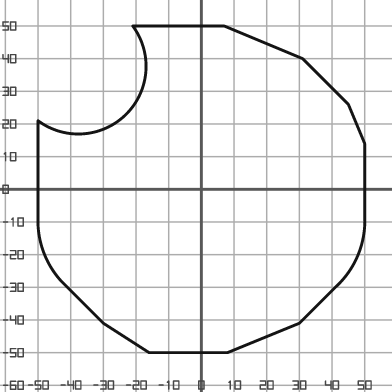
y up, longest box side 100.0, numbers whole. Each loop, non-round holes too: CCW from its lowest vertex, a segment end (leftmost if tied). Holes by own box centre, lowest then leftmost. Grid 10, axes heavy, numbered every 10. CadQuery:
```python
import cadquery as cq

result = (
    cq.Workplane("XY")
    .moveTo(-16.0, -50.0)
    .lineTo(8.0, -50.0)
    .lineTo(30.0, -41.0)
    .lineTo(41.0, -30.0)
    .threePointArc((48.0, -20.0), (50.0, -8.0))
    .lineTo(50.0, 14.0)
    .lineTo(45.0, 26.0)
    .lineTo(31.0, 40.0)
    .lineTo(7.0, 50.0)
    .lineTo(-21.0, 50.0)
    .threePointArc((-23.0, 23.0), (-50.0, 21.0))
    .lineTo(-50.0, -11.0)
    .threePointArc((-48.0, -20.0), (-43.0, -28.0))
    .lineTo(-30.0, -41.0)
    .close()
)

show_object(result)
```